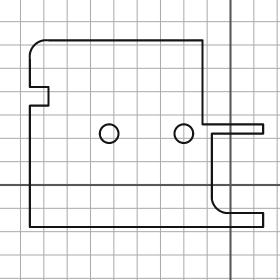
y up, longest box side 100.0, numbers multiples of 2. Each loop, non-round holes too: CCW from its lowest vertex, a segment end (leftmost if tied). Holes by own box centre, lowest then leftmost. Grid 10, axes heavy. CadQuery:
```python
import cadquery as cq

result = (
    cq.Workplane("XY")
    .moveTo(-86.0, -18.0)
    .lineTo(14.0, -18.0)
    .lineTo(14.0, -12.0)
    .lineTo(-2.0, -12.0)
    .threePointArc((-6.0, -10.0), (-8.0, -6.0))
    .lineTo(-8.0, 22.0)
    .lineTo(14.0, 22.0)
    .lineTo(14.0, 26.0)
    .lineTo(-12.0, 26.0)
    .lineTo(-12.0, 62.0)
    .lineTo(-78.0, 62.0)
    .threePointArc((-84.0, 60.0), (-86.0, 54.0))
    .lineTo(-86.0, 42.0)
    .lineTo(-78.0, 42.0)
    .lineTo(-78.0, 34.0)
    .lineTo(-86.0, 34.0)
    .close()
    .moveTo(-52.0, 22.0)
    .circle(4.0)
    .moveTo(-20.0, 22.0)
    .circle(4.0)
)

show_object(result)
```